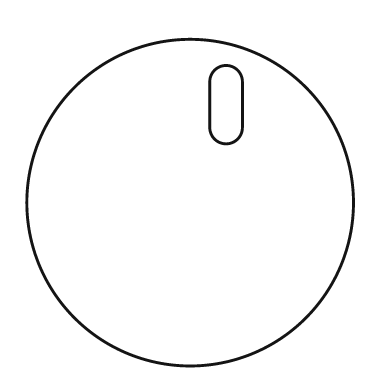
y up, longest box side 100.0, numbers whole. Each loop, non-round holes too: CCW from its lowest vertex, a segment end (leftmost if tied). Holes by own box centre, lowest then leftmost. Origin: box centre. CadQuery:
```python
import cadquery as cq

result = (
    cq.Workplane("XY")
    .moveTo(0.0, 0.0)
    .circle(50.0)
    .moveTo(6.0, 23.0)
    .threePointArc((11.0, 18.0), (16.0, 23.0))
    .lineTo(16.0, 37.0)
    .threePointArc((11.0, 42.0), (6.0, 37.0))
    .close()
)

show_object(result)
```